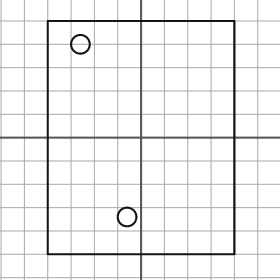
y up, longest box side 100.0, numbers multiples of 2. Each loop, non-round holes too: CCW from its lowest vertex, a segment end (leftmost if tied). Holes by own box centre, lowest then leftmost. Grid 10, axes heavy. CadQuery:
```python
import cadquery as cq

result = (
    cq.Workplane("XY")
    .moveTo(-40.0, -50.0)
    .lineTo(40.0, -50.0)
    .lineTo(40.0, 50.0)
    .lineTo(-40.0, 50.0)
    .close()
    .moveTo(-6.0, -34.0)
    .circle(4.0)
    .moveTo(-26.0, 40.0)
    .circle(4.0)
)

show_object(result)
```